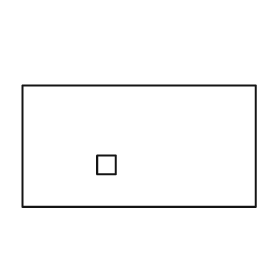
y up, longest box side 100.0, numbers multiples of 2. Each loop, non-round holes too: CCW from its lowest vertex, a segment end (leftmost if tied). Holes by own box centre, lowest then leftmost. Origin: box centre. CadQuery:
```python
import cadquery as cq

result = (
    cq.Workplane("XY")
    .moveTo(-50.0, -26.0)
    .lineTo(50.0, -26.0)
    .lineTo(50.0, 26.0)
    .lineTo(-50.0, 26.0)
    .close()
    .moveTo(-18.0, -12.0)
    .lineTo(-10.0, -12.0)
    .lineTo(-10.0, -4.0)
    .lineTo(-18.0, -4.0)
    .close()
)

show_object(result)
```